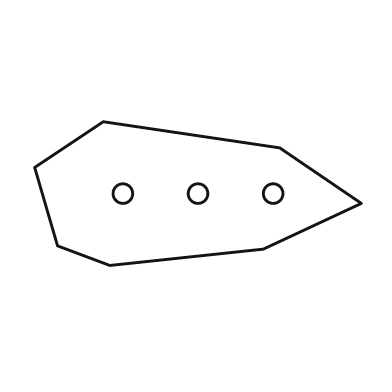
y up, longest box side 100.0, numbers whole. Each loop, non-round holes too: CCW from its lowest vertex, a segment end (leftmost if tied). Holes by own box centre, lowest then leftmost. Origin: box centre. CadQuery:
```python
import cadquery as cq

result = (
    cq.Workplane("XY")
    .moveTo(-27.0, -22.0)
    .lineTo(20.0, -17.0)
    .lineTo(50.0, -3.0)
    .lineTo(25.0, 14.0)
    .lineTo(-29.0, 22.0)
    .lineTo(-50.0, 8.0)
    .lineTo(-43.0, -16.0)
    .close()
    .moveTo(-23.0, 0.0)
    .circle(3.0)
    .moveTo(0.0, 0.0)
    .circle(3.0)
    .moveTo(23.0, 0.0)
    .circle(3.0)
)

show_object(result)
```